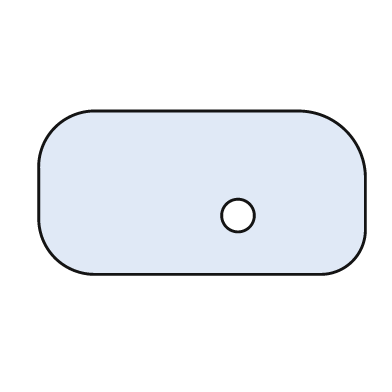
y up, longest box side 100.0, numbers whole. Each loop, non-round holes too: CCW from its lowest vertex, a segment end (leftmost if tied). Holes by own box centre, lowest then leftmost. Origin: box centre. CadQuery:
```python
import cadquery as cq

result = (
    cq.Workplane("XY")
    .moveTo(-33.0, -25.0)
    .lineTo(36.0, -25.0)
    .threePointArc((46.0, -21.0), (50.0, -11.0))
    .lineTo(50.0, 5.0)
    .threePointArc((44.0, 19.0), (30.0, 25.0))
    .lineTo(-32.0, 25.0)
    .threePointArc((-45.0, 20.0), (-50.0, 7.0))
    .lineTo(-50.0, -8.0)
    .threePointArc((-45.0, -20.0), (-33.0, -25.0))
    .close()
    .moveTo(11.0, -7.0)
    .circle(5.0)
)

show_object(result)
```